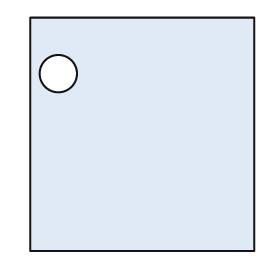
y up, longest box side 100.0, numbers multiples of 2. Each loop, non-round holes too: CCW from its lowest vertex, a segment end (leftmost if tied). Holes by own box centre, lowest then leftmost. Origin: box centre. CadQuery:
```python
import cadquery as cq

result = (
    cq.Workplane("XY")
    .moveTo(-48.0, -50.0)
    .lineTo(48.0, -50.0)
    .lineTo(48.0, 50.0)
    .lineTo(-48.0, 50.0)
    .close()
    .moveTo(-36.0, 26.0)
    .circle(8.0)
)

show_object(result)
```